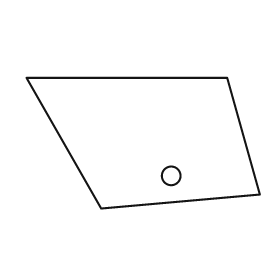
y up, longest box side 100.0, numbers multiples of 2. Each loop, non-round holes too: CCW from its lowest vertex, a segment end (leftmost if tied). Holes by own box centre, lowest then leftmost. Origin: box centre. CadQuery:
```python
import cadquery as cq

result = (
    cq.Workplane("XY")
    .moveTo(-18.0, -28.0)
    .lineTo(50.0, -22.0)
    .lineTo(36.0, 28.0)
    .lineTo(-50.0, 28.0)
    .close()
    .moveTo(12.0, -14.0)
    .circle(4.0)
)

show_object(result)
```